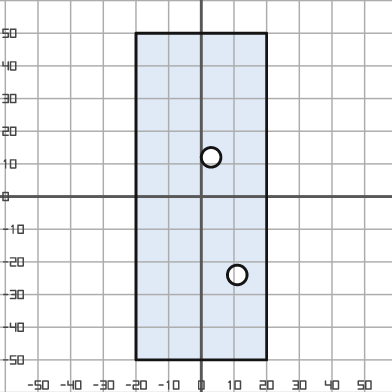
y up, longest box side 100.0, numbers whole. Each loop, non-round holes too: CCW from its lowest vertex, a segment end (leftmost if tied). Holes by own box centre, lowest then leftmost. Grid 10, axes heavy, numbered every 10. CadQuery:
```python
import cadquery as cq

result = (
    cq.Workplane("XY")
    .moveTo(-20.0, -50.0)
    .lineTo(20.0, -50.0)
    .lineTo(20.0, 50.0)
    .lineTo(-20.0, 50.0)
    .close()
    .moveTo(11.0, -24.0)
    .circle(3.0)
    .moveTo(3.0, 12.0)
    .circle(3.0)
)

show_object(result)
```